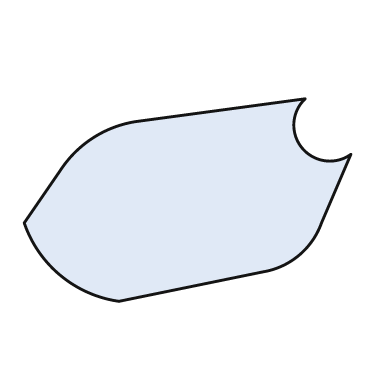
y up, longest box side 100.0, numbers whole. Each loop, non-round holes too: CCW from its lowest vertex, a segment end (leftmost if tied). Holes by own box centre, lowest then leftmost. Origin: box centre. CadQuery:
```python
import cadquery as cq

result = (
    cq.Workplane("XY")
    .moveTo(-21.0, -31.0)
    .lineTo(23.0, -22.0)
    .threePointArc((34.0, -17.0), (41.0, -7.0))
    .lineTo(50.0, 14.0)
    .threePointArc((35.0, 16.0), (36.0, 31.0))
    .lineTo(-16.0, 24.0)
    .threePointArc((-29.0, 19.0), (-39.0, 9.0))
    .lineTo(-50.0, -7.0)
    .threePointArc((-39.0, -23.0), (-21.0, -31.0))
    .close()
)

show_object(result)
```